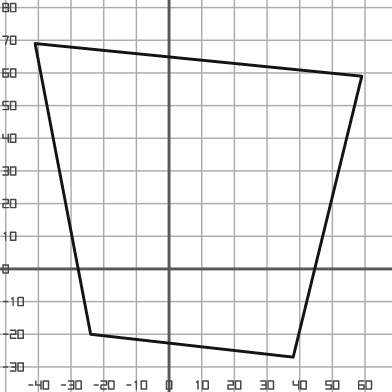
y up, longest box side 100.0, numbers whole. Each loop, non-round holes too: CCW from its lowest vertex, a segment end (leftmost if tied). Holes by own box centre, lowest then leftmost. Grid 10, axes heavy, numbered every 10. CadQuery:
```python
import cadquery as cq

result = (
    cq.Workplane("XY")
    .moveTo(38.0, -27.0)
    .lineTo(59.0, 59.0)
    .lineTo(-41.0, 69.0)
    .lineTo(-24.0, -20.0)
    .close()
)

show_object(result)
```